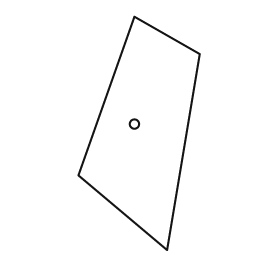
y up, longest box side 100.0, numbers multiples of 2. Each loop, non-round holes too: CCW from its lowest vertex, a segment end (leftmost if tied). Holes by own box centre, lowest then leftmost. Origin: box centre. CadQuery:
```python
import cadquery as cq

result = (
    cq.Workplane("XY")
    .moveTo(12.0, -50.0)
    .lineTo(26.0, 34.0)
    .lineTo(-2.0, 50.0)
    .lineTo(-26.0, -18.0)
    .close()
    .moveTo(-2.0, 4.0)
    .circle(2.0)
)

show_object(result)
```